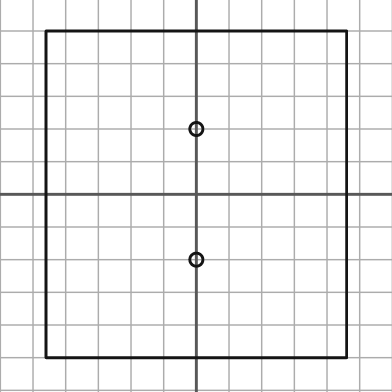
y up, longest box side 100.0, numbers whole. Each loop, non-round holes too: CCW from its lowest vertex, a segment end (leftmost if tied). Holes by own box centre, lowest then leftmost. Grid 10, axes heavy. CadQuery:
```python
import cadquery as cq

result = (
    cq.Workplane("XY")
    .moveTo(-46.0, -50.0)
    .lineTo(46.0, -50.0)
    .lineTo(46.0, 50.0)
    .lineTo(-46.0, 50.0)
    .close()
    .moveTo(0.0, -20.0)
    .circle(2.0)
    .moveTo(0.0, 20.0)
    .circle(2.0)
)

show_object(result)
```